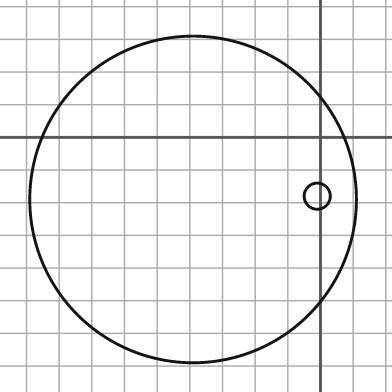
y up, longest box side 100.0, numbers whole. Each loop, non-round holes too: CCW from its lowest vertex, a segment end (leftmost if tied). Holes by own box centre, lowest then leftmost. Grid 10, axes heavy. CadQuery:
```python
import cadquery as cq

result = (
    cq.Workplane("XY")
    .moveTo(-39.0, -19.0)
    .circle(50.0)
    .moveTo(-1.0, -18.0)
    .circle(4.0)
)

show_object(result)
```